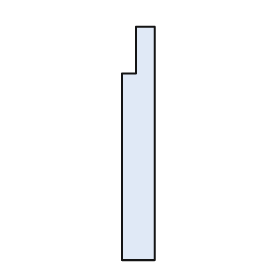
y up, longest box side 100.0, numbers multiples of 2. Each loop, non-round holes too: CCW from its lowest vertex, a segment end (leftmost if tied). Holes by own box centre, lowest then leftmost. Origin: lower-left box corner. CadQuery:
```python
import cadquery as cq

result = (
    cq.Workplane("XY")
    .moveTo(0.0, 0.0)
    .lineTo(14.0, 0.0)
    .lineTo(14.0, 100.0)
    .lineTo(6.0, 100.0)
    .lineTo(6.0, 80.0)
    .lineTo(0.0, 80.0)
    .close()
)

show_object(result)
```